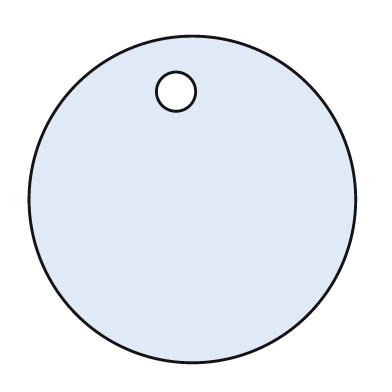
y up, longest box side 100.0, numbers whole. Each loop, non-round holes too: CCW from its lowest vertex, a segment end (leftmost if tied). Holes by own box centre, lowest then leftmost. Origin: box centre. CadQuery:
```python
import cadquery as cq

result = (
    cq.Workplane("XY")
    .moveTo(0.0, 0.0)
    .circle(50.0)
    .moveTo(-5.0, 33.0)
    .circle(6.0)
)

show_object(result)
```